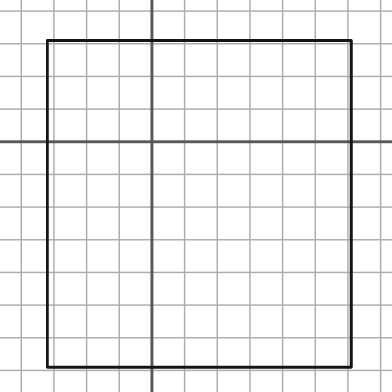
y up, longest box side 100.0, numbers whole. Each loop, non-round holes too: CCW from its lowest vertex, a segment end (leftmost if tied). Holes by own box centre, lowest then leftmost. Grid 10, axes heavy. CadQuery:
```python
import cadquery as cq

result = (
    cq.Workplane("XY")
    .moveTo(-32.0, -69.0)
    .lineTo(61.0, -69.0)
    .lineTo(61.0, 31.0)
    .lineTo(-32.0, 31.0)
    .close()
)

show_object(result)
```